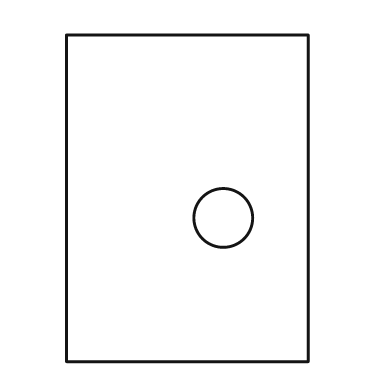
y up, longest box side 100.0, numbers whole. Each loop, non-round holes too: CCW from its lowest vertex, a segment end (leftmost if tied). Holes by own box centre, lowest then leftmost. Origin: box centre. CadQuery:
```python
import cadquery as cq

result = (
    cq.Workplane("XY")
    .moveTo(-37.0, -50.0)
    .lineTo(37.0, -50.0)
    .lineTo(37.0, 50.0)
    .lineTo(-37.0, 50.0)
    .close()
    .moveTo(11.0, -6.0)
    .circle(9.0)
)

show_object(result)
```